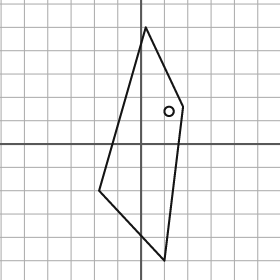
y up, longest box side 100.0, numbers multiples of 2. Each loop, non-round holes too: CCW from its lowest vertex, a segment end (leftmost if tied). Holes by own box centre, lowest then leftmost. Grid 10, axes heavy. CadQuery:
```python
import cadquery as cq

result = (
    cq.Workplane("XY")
    .moveTo(10.0, -50.0)
    .lineTo(18.0, 16.0)
    .lineTo(2.0, 50.0)
    .lineTo(-18.0, -20.0)
    .close()
    .moveTo(12.0, 14.0)
    .circle(2.0)
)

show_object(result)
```